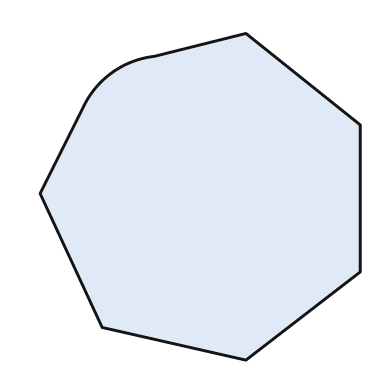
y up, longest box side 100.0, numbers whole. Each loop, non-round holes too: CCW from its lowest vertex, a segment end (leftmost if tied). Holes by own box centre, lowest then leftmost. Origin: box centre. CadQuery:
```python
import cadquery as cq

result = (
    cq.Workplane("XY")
    .moveTo(14.0, -50.0)
    .lineTo(49.0, -23.0)
    .lineTo(49.0, 22.0)
    .lineTo(14.0, 50.0)
    .lineTo(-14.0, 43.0)
    .threePointArc((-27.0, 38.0), (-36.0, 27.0))
    .lineTo(-49.0, 1.0)
    .lineTo(-30.0, -40.0)
    .close()
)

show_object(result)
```